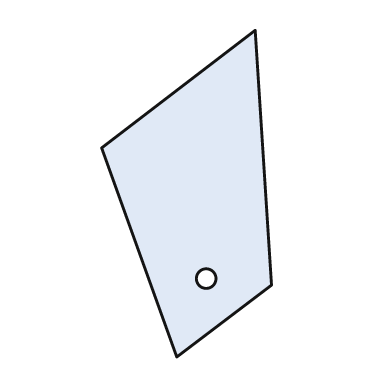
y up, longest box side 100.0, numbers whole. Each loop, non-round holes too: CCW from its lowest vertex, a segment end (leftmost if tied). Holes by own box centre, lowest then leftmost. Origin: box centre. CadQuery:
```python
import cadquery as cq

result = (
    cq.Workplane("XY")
    .moveTo(-3.0, -50.0)
    .lineTo(26.0, -28.0)
    .lineTo(21.0, 50.0)
    .lineTo(-26.0, 14.0)
    .close()
    .moveTo(6.0, -26.0)
    .circle(3.0)
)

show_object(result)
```